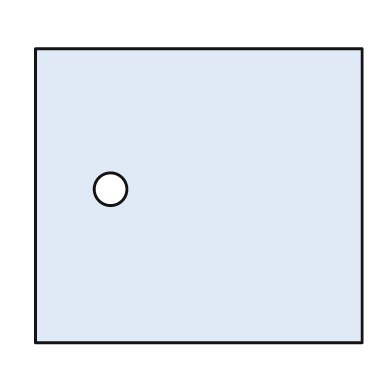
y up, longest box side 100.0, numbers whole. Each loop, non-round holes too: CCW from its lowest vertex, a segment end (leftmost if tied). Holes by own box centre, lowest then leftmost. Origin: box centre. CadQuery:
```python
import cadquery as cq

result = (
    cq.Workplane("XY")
    .moveTo(-50.0, -45.0)
    .lineTo(50.0, -45.0)
    .lineTo(50.0, 45.0)
    .lineTo(-50.0, 45.0)
    .close()
    .moveTo(-27.0, 2.0)
    .circle(5.0)
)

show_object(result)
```